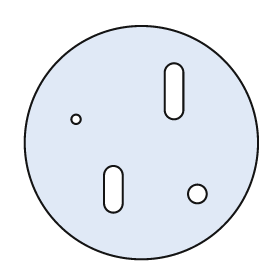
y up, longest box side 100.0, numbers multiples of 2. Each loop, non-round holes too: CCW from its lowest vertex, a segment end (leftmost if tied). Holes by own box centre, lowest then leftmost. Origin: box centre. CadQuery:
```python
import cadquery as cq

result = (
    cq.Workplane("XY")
    .moveTo(0.0, 0.0)
    .circle(50.0)
    .moveTo(24.0, -22.0)
    .circle(4.0)
    .moveTo(-16.0, -26.0)
    .threePointArc((-12.0, -30.0), (-8.0, -26.0))
    .lineTo(-8.0, -14.0)
    .threePointArc((-12.0, -10.0), (-16.0, -14.0))
    .close()
    .moveTo(-28.0, 10.0)
    .circle(2.0)
    .moveTo(10.0, 14.0)
    .threePointArc((14.0, 10.0), (18.0, 14.0))
    .lineTo(18.0, 30.0)
    .threePointArc((14.0, 34.0), (10.0, 30.0))
    .close()
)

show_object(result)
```